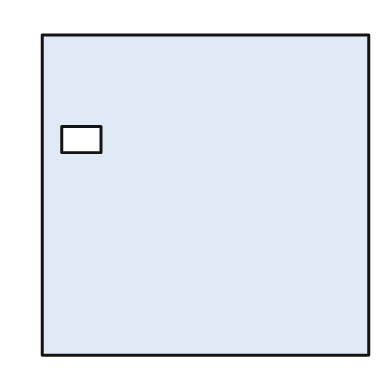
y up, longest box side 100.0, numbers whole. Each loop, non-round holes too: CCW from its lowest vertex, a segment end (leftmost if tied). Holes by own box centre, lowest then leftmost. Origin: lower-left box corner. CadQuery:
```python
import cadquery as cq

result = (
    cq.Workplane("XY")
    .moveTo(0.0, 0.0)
    .lineTo(100.0, 0.0)
    .lineTo(100.0, 98.0)
    .lineTo(0.0, 98.0)
    .close()
    .moveTo(6.0, 62.0)
    .lineTo(18.0, 62.0)
    .lineTo(18.0, 70.0)
    .lineTo(6.0, 70.0)
    .close()
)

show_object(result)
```